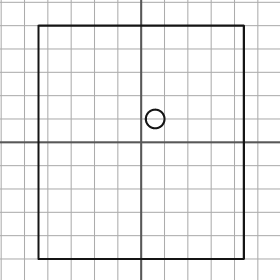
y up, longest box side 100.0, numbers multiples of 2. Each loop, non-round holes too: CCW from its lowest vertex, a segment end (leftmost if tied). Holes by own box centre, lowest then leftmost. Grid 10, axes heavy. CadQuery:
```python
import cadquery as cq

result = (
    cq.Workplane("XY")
    .moveTo(-44.0, -50.0)
    .lineTo(44.0, -50.0)
    .lineTo(44.0, 50.0)
    .lineTo(-44.0, 50.0)
    .close()
    .moveTo(6.0, 10.0)
    .circle(4.0)
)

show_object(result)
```